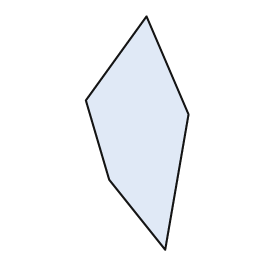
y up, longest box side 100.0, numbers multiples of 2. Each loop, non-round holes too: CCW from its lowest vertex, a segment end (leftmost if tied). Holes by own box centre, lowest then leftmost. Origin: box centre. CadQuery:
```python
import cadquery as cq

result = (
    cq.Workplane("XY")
    .moveTo(12.0, -50.0)
    .lineTo(22.0, 8.0)
    .lineTo(4.0, 50.0)
    .lineTo(-22.0, 14.0)
    .lineTo(-12.0, -20.0)
    .close()
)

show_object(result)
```